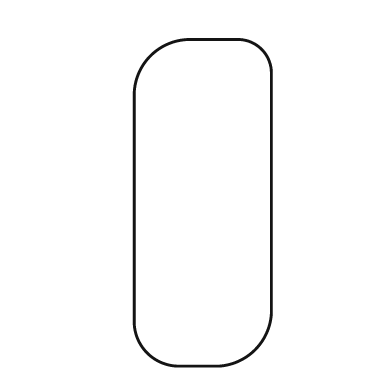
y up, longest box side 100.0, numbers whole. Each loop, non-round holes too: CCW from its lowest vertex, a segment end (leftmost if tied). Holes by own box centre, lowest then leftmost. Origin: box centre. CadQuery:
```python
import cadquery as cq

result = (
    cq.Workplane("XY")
    .moveTo(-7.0, -50.0)
    .lineTo(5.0, -50.0)
    .threePointArc((16.0, -45.0), (21.0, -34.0))
    .lineTo(21.0, 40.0)
    .threePointArc((18.0, 47.0), (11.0, 50.0))
    .lineTo(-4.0, 50.0)
    .threePointArc((-16.0, 45.0), (-21.0, 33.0))
    .lineTo(-21.0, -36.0)
    .threePointArc((-17.0, -46.0), (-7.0, -50.0))
    .close()
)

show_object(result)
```